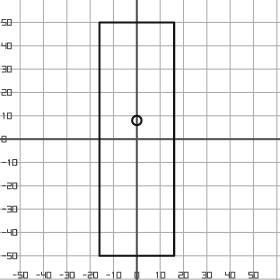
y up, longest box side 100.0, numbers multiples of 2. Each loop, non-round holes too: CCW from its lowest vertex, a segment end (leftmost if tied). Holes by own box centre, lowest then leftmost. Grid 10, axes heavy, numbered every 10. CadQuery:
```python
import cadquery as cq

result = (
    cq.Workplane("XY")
    .moveTo(-16.0, -50.0)
    .lineTo(16.0, -50.0)
    .lineTo(16.0, 50.0)
    .lineTo(-16.0, 50.0)
    .close()
    .moveTo(0.0, 8.0)
    .circle(2.0)
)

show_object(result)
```